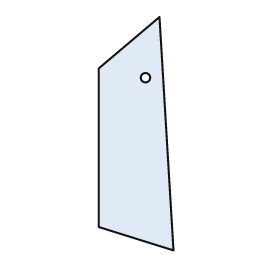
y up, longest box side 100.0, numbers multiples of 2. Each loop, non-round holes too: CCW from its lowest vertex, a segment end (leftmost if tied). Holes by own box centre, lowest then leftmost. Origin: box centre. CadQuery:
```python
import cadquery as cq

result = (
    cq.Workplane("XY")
    .moveTo(16.0, -50.0)
    .lineTo(10.0, 50.0)
    .lineTo(-16.0, 28.0)
    .lineTo(-16.0, -40.0)
    .close()
    .moveTo(4.0, 24.0)
    .circle(2.0)
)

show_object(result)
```